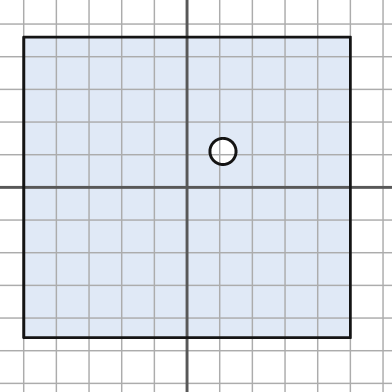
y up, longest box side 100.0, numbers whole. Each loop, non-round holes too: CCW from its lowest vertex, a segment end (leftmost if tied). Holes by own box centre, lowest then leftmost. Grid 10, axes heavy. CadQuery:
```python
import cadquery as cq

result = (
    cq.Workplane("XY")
    .moveTo(-50.0, -46.0)
    .lineTo(50.0, -46.0)
    .lineTo(50.0, 46.0)
    .lineTo(-50.0, 46.0)
    .close()
    .moveTo(11.0, 11.0)
    .circle(4.0)
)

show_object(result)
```